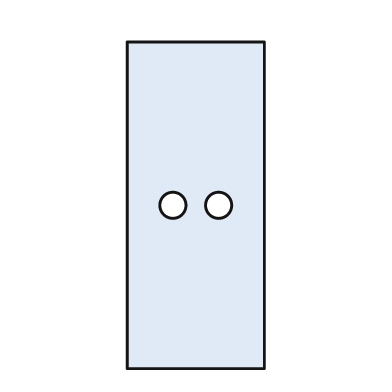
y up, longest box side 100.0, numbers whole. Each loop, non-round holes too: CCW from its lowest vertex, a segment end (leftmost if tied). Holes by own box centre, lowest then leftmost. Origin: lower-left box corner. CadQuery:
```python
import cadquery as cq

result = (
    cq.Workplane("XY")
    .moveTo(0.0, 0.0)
    .lineTo(42.0, 0.0)
    .lineTo(42.0, 100.0)
    .lineTo(0.0, 100.0)
    .close()
    .moveTo(14.0, 50.0)
    .circle(4.0)
    .moveTo(28.0, 50.0)
    .circle(4.0)
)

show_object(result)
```